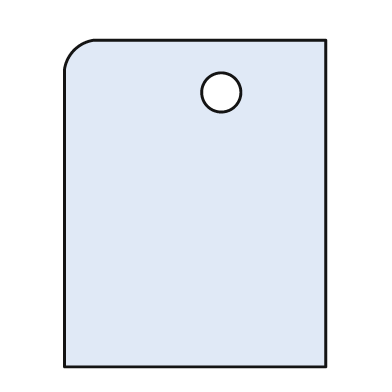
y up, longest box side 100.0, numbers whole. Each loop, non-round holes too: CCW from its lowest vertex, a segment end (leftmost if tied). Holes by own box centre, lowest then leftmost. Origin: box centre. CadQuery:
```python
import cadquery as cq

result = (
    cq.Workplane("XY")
    .moveTo(-40.0, -50.0)
    .lineTo(40.0, -50.0)
    .lineTo(40.0, 50.0)
    .lineTo(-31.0, 50.0)
    .threePointArc((-37.0, 47.0), (-40.0, 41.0))
    .close()
    .moveTo(8.0, 34.0)
    .circle(6.0)
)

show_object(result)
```